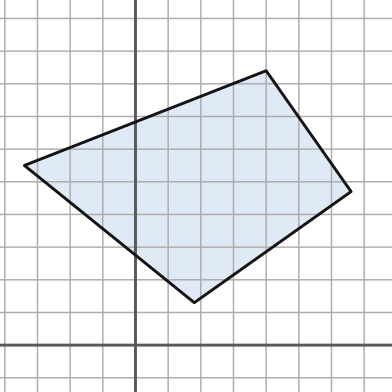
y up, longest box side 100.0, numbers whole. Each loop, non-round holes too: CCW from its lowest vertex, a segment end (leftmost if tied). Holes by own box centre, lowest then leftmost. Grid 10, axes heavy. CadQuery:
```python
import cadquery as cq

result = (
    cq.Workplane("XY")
    .moveTo(18.0, 13.0)
    .lineTo(66.0, 47.0)
    .lineTo(40.0, 84.0)
    .lineTo(-34.0, 55.0)
    .close()
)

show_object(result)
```